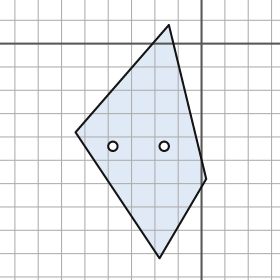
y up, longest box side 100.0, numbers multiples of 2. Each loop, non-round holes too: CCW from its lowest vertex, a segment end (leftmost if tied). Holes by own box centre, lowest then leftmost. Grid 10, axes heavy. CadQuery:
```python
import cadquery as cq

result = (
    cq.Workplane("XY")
    .moveTo(-18.0, -92.0)
    .lineTo(2.0, -58.0)
    .lineTo(-14.0, 8.0)
    .lineTo(-54.0, -38.0)
    .close()
    .moveTo(-38.0, -44.0)
    .circle(2.0)
    .moveTo(-16.0, -44.0)
    .circle(2.0)
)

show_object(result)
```